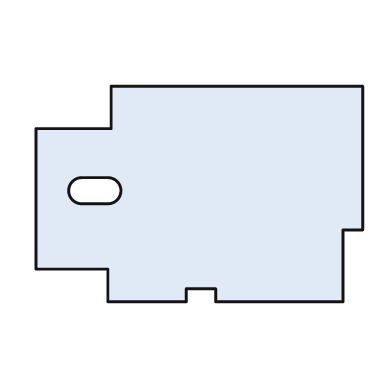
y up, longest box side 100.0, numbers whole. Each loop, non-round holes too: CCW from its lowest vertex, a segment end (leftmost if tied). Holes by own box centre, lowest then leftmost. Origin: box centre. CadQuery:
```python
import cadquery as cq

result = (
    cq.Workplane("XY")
    .moveTo(-28.0, -33.0)
    .lineTo(-4.0, -33.0)
    .lineTo(-4.0, -29.0)
    .lineTo(5.0, -29.0)
    .lineTo(5.0, -33.0)
    .lineTo(44.0, -33.0)
    .lineTo(44.0, -11.0)
    .lineTo(50.0, -11.0)
    .lineTo(50.0, 33.0)
    .lineTo(-27.0, 33.0)
    .lineTo(-27.0, 20.0)
    .lineTo(-50.0, 20.0)
    .lineTo(-50.0, -23.0)
    .lineTo(-28.0, -23.0)
    .close()
    .moveTo(-36.0, -3.0)
    .lineTo(-28.0, -3.0)
    .threePointArc((-24.0, 1.0), (-28.0, 5.0))
    .lineTo(-36.0, 5.0)
    .threePointArc((-40.0, 1.0), (-36.0, -3.0))
    .close()
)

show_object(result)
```